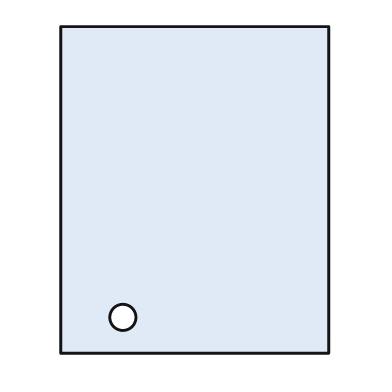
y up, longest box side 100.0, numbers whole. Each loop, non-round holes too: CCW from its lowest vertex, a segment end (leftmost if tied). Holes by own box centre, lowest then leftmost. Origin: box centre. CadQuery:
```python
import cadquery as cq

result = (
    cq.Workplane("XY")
    .moveTo(-41.0, -50.0)
    .lineTo(41.0, -50.0)
    .lineTo(41.0, 50.0)
    .lineTo(-41.0, 50.0)
    .close()
    .moveTo(-22.0, -39.0)
    .circle(4.0)
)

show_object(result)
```